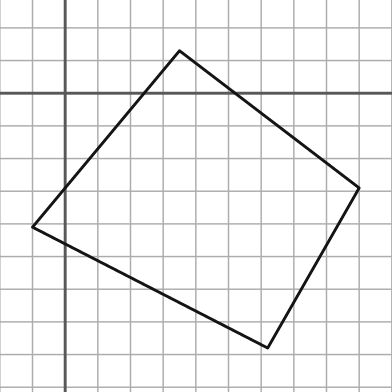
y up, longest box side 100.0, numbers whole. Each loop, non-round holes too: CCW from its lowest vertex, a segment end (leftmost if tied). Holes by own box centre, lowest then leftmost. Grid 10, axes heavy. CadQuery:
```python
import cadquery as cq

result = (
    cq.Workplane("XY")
    .moveTo(62.0, -78.0)
    .lineTo(90.0, -29.0)
    .lineTo(35.0, 13.0)
    .lineTo(-10.0, -41.0)
    .close()
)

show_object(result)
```